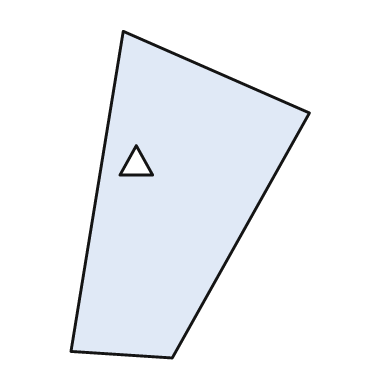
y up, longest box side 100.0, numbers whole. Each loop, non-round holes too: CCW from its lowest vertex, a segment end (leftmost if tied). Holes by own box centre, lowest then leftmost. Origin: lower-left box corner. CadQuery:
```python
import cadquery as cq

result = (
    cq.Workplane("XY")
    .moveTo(31.0, 0.0)
    .lineTo(73.0, 75.0)
    .lineTo(16.0, 100.0)
    .lineTo(0.0, 2.0)
    .close()
    .moveTo(15.0, 56.0)
    .lineTo(25.0, 56.0)
    .lineTo(20.0, 65.0)
    .close()
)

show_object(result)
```